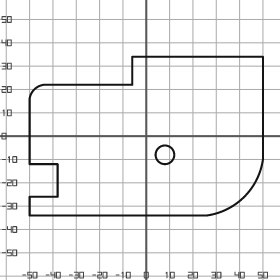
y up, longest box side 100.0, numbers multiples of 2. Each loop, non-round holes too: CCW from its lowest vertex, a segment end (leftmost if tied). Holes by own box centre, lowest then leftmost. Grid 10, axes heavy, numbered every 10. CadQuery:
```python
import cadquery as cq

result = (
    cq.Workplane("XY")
    .moveTo(-50.0, -34.0)
    .lineTo(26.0, -34.0)
    .threePointArc((42.0, -26.0), (50.0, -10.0))
    .lineTo(50.0, 34.0)
    .lineTo(-6.0, 34.0)
    .lineTo(-6.0, 22.0)
    .lineTo(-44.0, 22.0)
    .threePointArc((-48.0, 20.0), (-50.0, 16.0))
    .lineTo(-50.0, -12.0)
    .lineTo(-38.0, -12.0)
    .lineTo(-38.0, -26.0)
    .lineTo(-50.0, -26.0)
    .close()
    .moveTo(8.0, -8.0)
    .circle(4.0)
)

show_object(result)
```